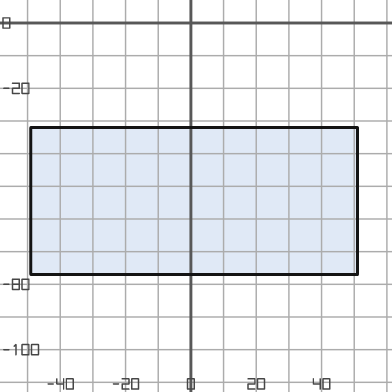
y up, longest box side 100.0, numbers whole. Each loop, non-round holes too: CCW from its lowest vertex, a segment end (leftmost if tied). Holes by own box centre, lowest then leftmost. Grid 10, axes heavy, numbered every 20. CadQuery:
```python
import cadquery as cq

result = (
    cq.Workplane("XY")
    .moveTo(-49.0, -77.0)
    .lineTo(51.0, -77.0)
    .lineTo(51.0, -32.0)
    .lineTo(-49.0, -32.0)
    .close()
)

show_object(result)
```